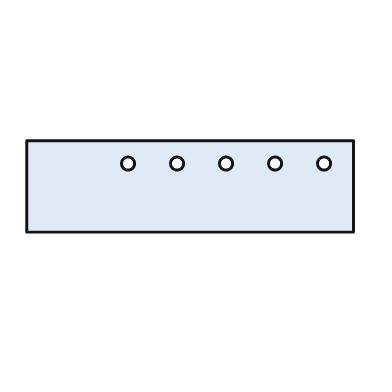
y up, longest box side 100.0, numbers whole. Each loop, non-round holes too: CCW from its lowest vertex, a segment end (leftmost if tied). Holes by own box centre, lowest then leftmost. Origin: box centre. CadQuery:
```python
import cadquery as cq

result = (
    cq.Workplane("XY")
    .moveTo(-50.0, -14.0)
    .lineTo(50.0, -14.0)
    .lineTo(50.0, 14.0)
    .lineTo(-50.0, 14.0)
    .close()
    .moveTo(-19.0, 7.0)
    .circle(2.0)
    .moveTo(-4.0, 7.0)
    .circle(2.0)
    .moveTo(11.0, 7.0)
    .circle(2.0)
    .moveTo(26.0, 7.0)
    .circle(2.0)
    .moveTo(41.0, 7.0)
    .circle(2.0)
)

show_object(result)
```